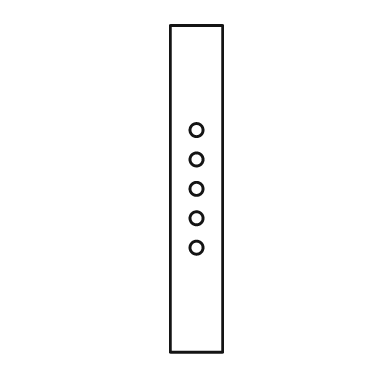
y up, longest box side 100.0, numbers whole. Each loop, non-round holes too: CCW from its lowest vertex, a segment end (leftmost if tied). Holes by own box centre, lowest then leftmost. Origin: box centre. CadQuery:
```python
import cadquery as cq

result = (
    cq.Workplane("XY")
    .moveTo(-8.0, -50.0)
    .lineTo(8.0, -50.0)
    .lineTo(8.0, 50.0)
    .lineTo(-8.0, 50.0)
    .close()
    .moveTo(0.0, -18.0)
    .circle(2.0)
    .moveTo(0.0, -9.0)
    .circle(2.0)
    .moveTo(0.0, 0.0)
    .circle(2.0)
    .moveTo(0.0, 9.0)
    .circle(2.0)
    .moveTo(0.0, 18.0)
    .circle(2.0)
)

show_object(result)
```